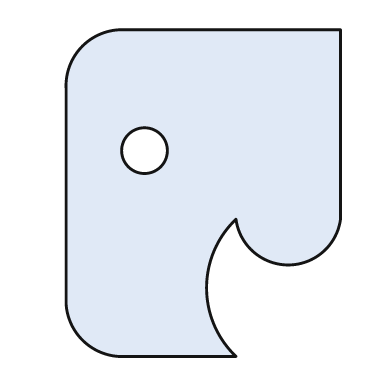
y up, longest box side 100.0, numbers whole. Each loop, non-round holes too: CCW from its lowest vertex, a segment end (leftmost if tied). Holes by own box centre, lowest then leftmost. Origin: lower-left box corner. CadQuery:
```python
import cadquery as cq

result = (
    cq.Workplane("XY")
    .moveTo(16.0, 0.0)
    .lineTo(52.0, 0.0)
    .threePointArc((43.0, 21.0), (52.0, 42.0))
    .threePointArc((68.0, 28.0), (84.0, 42.0))
    .lineTo(84.0, 100.0)
    .lineTo(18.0, 100.0)
    .threePointArc((5.0, 95.0), (0.0, 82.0))
    .lineTo(0.0, 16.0)
    .threePointArc((5.0, 5.0), (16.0, 0.0))
    .close()
    .moveTo(24.0, 63.0)
    .circle(7.0)
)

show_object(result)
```